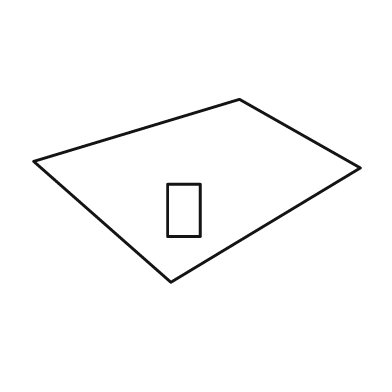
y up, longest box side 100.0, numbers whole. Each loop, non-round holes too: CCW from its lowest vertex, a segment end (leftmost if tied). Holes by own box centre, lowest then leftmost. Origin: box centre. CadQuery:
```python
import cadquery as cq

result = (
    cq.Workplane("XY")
    .moveTo(-8.0, -28.0)
    .lineTo(50.0, 7.0)
    .lineTo(13.0, 28.0)
    .lineTo(-50.0, 9.0)
    .close()
    .moveTo(-9.0, -14.0)
    .lineTo(1.0, -14.0)
    .lineTo(1.0, 2.0)
    .lineTo(-9.0, 2.0)
    .close()
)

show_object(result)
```